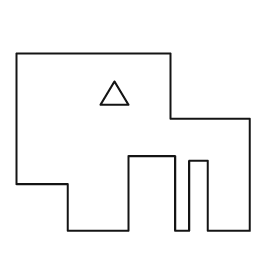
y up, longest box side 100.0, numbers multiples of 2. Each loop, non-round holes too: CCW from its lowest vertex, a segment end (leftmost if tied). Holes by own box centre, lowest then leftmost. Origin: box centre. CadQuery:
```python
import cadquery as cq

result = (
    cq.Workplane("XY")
    .moveTo(-28.0, -38.0)
    .lineTo(-2.0, -38.0)
    .lineTo(-2.0, -6.0)
    .lineTo(18.0, -6.0)
    .lineTo(18.0, -38.0)
    .lineTo(24.0, -38.0)
    .lineTo(24.0, -8.0)
    .lineTo(32.0, -8.0)
    .lineTo(32.0, -38.0)
    .lineTo(50.0, -38.0)
    .lineTo(50.0, 10.0)
    .lineTo(16.0, 10.0)
    .lineTo(16.0, 38.0)
    .lineTo(-50.0, 38.0)
    .lineTo(-50.0, -18.0)
    .lineTo(-28.0, -18.0)
    .close()
    .moveTo(-14.0, 16.0)
    .lineTo(-2.0, 16.0)
    .lineTo(-8.0, 26.0)
    .close()
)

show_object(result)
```